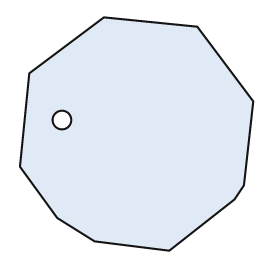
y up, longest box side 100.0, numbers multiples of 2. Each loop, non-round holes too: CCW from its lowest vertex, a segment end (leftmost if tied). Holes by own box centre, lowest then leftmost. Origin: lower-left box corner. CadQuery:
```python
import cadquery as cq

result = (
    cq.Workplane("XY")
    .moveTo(64.0, 0.0)
    .lineTo(92.0, 22.0)
    .lineTo(96.0, 28.0)
    .lineTo(100.0, 64.0)
    .lineTo(76.0, 96.0)
    .lineTo(36.0, 100.0)
    .lineTo(4.0, 76.0)
    .lineTo(0.0, 36.0)
    .lineTo(16.0, 14.0)
    .lineTo(32.0, 4.0)
    .close()
    .moveTo(18.0, 56.0)
    .circle(4.0)
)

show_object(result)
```